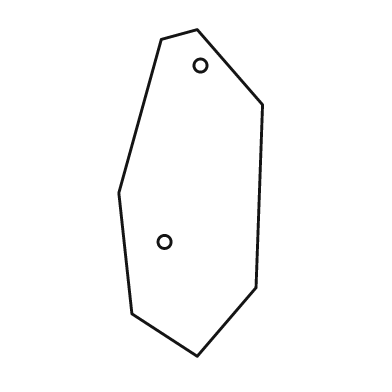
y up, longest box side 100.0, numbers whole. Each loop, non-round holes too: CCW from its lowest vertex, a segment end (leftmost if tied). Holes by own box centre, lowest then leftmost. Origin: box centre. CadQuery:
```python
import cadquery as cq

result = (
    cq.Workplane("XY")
    .moveTo(2.0, -50.0)
    .lineTo(20.0, -29.0)
    .lineTo(22.0, 27.0)
    .lineTo(2.0, 50.0)
    .lineTo(-9.0, 47.0)
    .lineTo(-22.0, 0.0)
    .lineTo(-18.0, -37.0)
    .close()
    .moveTo(-8.0, -15.0)
    .circle(2.0)
    .moveTo(3.0, 39.0)
    .circle(2.0)
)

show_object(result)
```